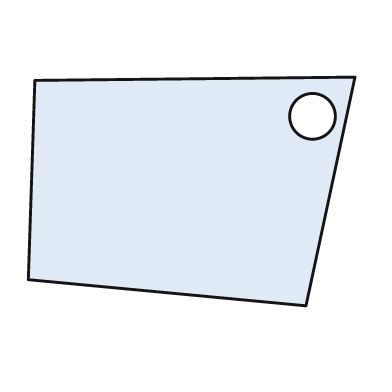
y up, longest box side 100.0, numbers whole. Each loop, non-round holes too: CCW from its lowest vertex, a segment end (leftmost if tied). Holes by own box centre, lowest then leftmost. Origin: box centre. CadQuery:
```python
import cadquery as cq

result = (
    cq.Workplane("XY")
    .moveTo(35.0, -35.0)
    .lineTo(50.0, 35.0)
    .lineTo(-48.0, 34.0)
    .lineTo(-50.0, -27.0)
    .close()
    .moveTo(37.0, 23.0)
    .circle(7.0)
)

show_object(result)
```